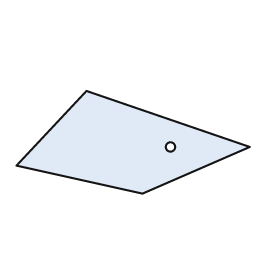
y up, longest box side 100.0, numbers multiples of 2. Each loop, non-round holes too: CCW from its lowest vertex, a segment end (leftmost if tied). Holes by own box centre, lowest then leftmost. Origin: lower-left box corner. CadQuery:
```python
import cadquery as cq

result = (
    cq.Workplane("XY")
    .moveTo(54.0, 0.0)
    .lineTo(100.0, 20.0)
    .lineTo(30.0, 44.0)
    .lineTo(0.0, 12.0)
    .close()
    .moveTo(66.0, 20.0)
    .circle(2.0)
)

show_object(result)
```